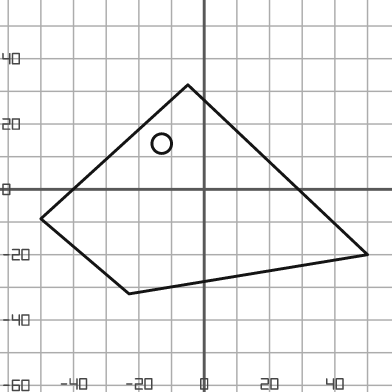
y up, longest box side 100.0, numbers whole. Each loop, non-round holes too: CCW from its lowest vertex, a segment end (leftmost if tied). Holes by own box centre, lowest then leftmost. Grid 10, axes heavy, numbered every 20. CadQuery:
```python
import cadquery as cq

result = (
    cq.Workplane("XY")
    .moveTo(-23.0, -32.0)
    .lineTo(50.0, -20.0)
    .lineTo(-5.0, 32.0)
    .lineTo(-50.0, -9.0)
    .close()
    .moveTo(-13.0, 14.0)
    .circle(3.0)
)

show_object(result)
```